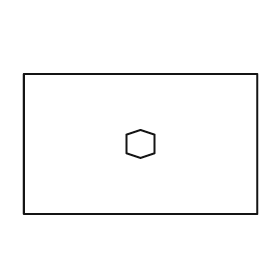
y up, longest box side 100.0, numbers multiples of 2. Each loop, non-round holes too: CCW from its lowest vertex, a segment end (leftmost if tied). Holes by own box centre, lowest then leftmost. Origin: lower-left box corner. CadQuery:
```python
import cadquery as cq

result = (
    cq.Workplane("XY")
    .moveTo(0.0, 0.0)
    .lineTo(100.0, 0.0)
    .lineTo(100.0, 60.0)
    .lineTo(0.0, 60.0)
    .close()
    .moveTo(50.0, 24.0)
    .lineTo(56.0, 26.0)
    .lineTo(56.0, 34.0)
    .lineTo(50.0, 36.0)
    .lineTo(44.0, 34.0)
    .lineTo(44.0, 26.0)
    .close()
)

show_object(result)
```